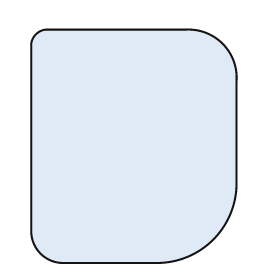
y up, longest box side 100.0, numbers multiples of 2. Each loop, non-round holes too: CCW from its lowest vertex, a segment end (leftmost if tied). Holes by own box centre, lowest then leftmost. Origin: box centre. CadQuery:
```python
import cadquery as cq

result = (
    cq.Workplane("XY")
    .moveTo(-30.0, -50.0)
    .lineTo(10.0, -50.0)
    .threePointArc((34.0, -40.0), (44.0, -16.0))
    .lineTo(44.0, 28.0)
    .threePointArc((38.0, 44.0), (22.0, 50.0))
    .lineTo(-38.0, 50.0)
    .threePointArc((-42.0, 48.0), (-44.0, 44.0))
    .lineTo(-44.0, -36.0)
    .threePointArc((-40.0, -46.0), (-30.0, -50.0))
    .close()
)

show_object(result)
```